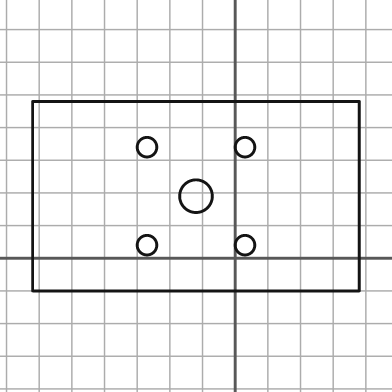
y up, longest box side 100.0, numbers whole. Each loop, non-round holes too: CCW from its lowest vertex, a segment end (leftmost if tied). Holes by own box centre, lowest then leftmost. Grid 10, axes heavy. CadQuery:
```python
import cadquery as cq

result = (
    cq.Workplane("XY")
    .moveTo(-62.0, -10.0)
    .lineTo(38.0, -10.0)
    .lineTo(38.0, 48.0)
    .lineTo(-62.0, 48.0)
    .close()
    .moveTo(-27.0, 4.0)
    .circle(3.0)
    .moveTo(3.0, 4.0)
    .circle(3.0)
    .moveTo(-12.0, 19.0)
    .circle(5.0)
    .moveTo(-27.0, 34.0)
    .circle(3.0)
    .moveTo(3.0, 34.0)
    .circle(3.0)
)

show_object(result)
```